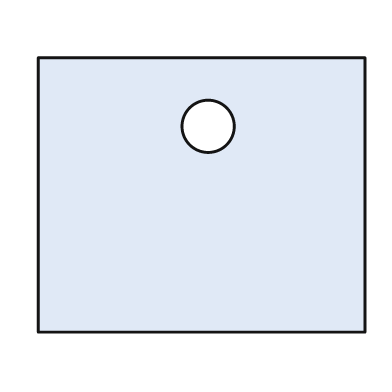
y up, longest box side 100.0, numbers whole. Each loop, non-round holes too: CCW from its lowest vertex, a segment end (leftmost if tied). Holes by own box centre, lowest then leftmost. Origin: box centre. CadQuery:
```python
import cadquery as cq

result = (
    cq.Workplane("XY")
    .moveTo(-50.0, -42.0)
    .lineTo(50.0, -42.0)
    .lineTo(50.0, 42.0)
    .lineTo(-50.0, 42.0)
    .close()
    .moveTo(2.0, 21.0)
    .circle(8.0)
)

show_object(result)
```